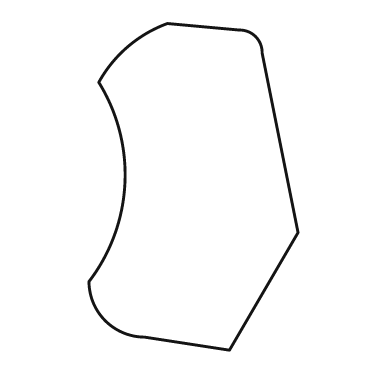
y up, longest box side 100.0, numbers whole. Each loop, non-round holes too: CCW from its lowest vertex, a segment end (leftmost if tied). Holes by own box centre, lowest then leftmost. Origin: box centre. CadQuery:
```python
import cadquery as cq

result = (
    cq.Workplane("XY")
    .moveTo(11.0, -50.0)
    .lineTo(32.0, -14.0)
    .lineTo(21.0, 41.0)
    .threePointArc((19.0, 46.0), (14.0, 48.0))
    .lineTo(-8.0, 50.0)
    .threePointArc((-20.0, 43.0), (-29.0, 32.0))
    .threePointArc((-21.0, 1.0), (-32.0, -29.0))
    .threePointArc((-27.0, -41.0), (-15.0, -46.0))
    .close()
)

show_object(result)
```